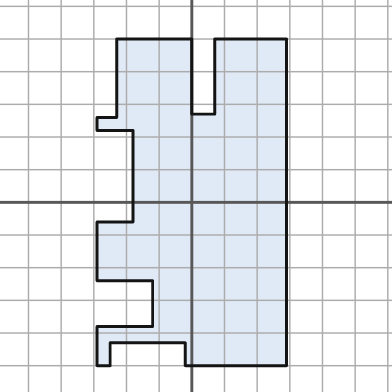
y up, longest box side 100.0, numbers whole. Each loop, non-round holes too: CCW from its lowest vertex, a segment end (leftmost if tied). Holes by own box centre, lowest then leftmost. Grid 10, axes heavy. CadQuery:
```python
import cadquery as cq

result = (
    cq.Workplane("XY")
    .moveTo(-29.0, -50.0)
    .lineTo(-25.0, -50.0)
    .lineTo(-25.0, -43.0)
    .lineTo(-2.0, -43.0)
    .lineTo(-2.0, -50.0)
    .lineTo(29.0, -50.0)
    .lineTo(29.0, 50.0)
    .lineTo(7.0, 50.0)
    .lineTo(7.0, 27.0)
    .lineTo(0.0, 27.0)
    .lineTo(0.0, 50.0)
    .lineTo(-23.0, 50.0)
    .lineTo(-23.0, 26.0)
    .lineTo(-29.0, 26.0)
    .lineTo(-29.0, 22.0)
    .lineTo(-18.0, 22.0)
    .lineTo(-18.0, -6.0)
    .lineTo(-29.0, -6.0)
    .lineTo(-29.0, -24.0)
    .lineTo(-12.0, -24.0)
    .lineTo(-12.0, -38.0)
    .lineTo(-29.0, -38.0)
    .close()
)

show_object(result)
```